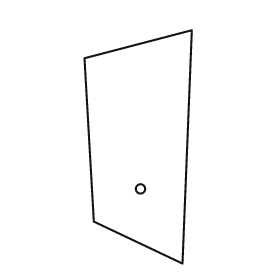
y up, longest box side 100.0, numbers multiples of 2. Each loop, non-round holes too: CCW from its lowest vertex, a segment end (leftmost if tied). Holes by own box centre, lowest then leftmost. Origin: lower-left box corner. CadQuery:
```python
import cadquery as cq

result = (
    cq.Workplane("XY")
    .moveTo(42.0, 0.0)
    .lineTo(46.0, 100.0)
    .lineTo(0.0, 88.0)
    .lineTo(4.0, 18.0)
    .close()
    .moveTo(24.0, 32.0)
    .circle(2.0)
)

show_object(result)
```